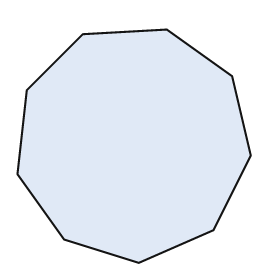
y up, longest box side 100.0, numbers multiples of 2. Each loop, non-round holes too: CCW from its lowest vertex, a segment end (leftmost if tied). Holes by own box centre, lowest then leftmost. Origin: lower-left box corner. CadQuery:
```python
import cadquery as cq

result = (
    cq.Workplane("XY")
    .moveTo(52.0, 0.0)
    .lineTo(84.0, 14.0)
    .lineTo(100.0, 46.0)
    .lineTo(92.0, 80.0)
    .lineTo(64.0, 100.0)
    .lineTo(28.0, 98.0)
    .lineTo(4.0, 74.0)
    .lineTo(0.0, 38.0)
    .lineTo(20.0, 10.0)
    .close()
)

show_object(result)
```